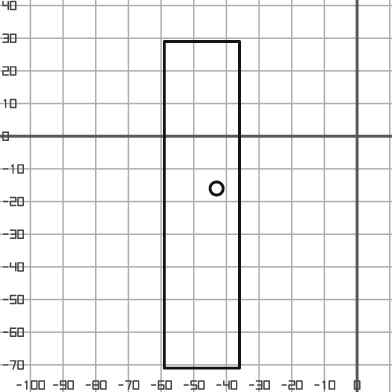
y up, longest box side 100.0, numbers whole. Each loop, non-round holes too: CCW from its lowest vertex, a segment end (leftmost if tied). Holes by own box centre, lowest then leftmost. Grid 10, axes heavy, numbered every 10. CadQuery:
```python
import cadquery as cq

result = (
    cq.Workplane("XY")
    .moveTo(-59.0, -71.0)
    .lineTo(-36.0, -71.0)
    .lineTo(-36.0, 29.0)
    .lineTo(-59.0, 29.0)
    .close()
    .moveTo(-43.0, -16.0)
    .circle(2.0)
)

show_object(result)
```